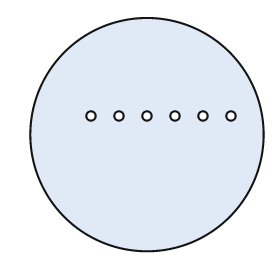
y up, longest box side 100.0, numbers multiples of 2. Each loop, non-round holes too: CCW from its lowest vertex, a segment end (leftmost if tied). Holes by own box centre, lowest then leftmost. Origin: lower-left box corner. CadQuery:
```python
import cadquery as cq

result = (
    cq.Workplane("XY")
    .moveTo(50.0, 50.0)
    .circle(50.0)
    .moveTo(26.0, 58.0)
    .circle(2.0)
    .moveTo(38.0, 58.0)
    .circle(2.0)
    .moveTo(50.0, 58.0)
    .circle(2.0)
    .moveTo(62.0, 58.0)
    .circle(2.0)
    .moveTo(74.0, 58.0)
    .circle(2.0)
    .moveTo(86.0, 58.0)
    .circle(2.0)
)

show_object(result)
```